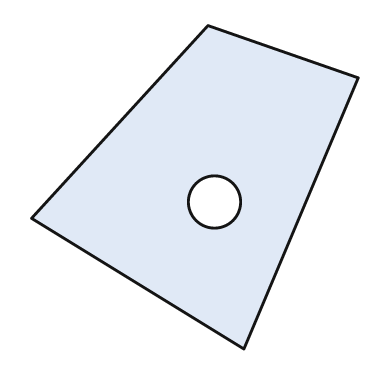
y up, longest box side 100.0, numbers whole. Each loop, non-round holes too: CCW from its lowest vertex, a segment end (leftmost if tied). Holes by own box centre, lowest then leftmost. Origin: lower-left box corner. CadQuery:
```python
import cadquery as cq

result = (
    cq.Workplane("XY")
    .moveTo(65.0, 0.0)
    .lineTo(100.0, 83.0)
    .lineTo(54.0, 99.0)
    .lineTo(0.0, 40.0)
    .close()
    .moveTo(56.0, 45.0)
    .circle(8.0)
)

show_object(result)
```